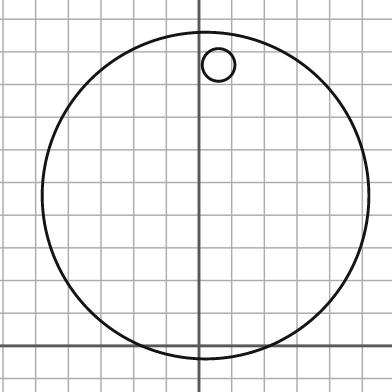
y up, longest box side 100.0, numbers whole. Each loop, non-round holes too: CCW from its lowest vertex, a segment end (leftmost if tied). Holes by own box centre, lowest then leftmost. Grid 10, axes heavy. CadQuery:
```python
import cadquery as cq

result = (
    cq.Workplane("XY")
    .moveTo(2.0, 46.0)
    .circle(50.0)
    .moveTo(6.0, 86.0)
    .circle(5.0)
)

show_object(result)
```